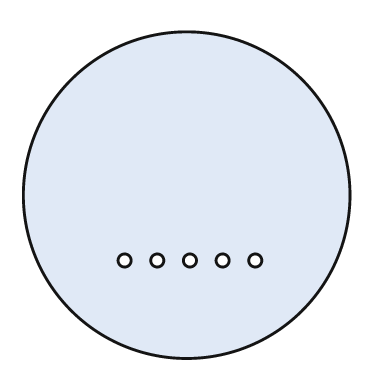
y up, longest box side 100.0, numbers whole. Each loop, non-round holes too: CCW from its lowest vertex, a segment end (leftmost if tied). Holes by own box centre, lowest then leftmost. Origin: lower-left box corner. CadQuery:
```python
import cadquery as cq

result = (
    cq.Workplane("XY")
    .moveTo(50.0, 50.0)
    .circle(50.0)
    .moveTo(31.0, 30.0)
    .circle(2.0)
    .moveTo(41.0, 30.0)
    .circle(2.0)
    .moveTo(51.0, 30.0)
    .circle(2.0)
    .moveTo(61.0, 30.0)
    .circle(2.0)
    .moveTo(71.0, 30.0)
    .circle(2.0)
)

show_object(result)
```